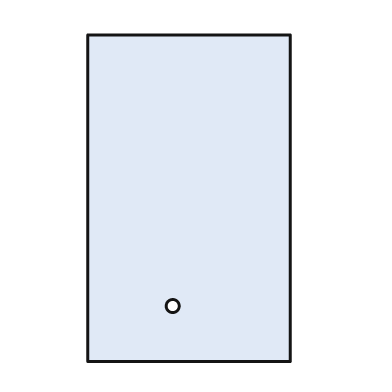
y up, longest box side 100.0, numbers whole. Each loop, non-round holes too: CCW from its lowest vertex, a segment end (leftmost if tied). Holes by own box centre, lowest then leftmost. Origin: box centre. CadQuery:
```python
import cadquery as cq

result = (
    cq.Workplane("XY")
    .moveTo(-31.0, -50.0)
    .lineTo(31.0, -50.0)
    .lineTo(31.0, 50.0)
    .lineTo(-31.0, 50.0)
    .close()
    .moveTo(-5.0, -33.0)
    .circle(2.0)
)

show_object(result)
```